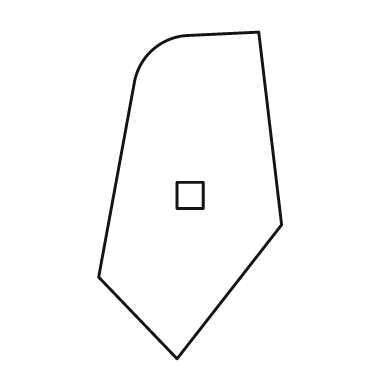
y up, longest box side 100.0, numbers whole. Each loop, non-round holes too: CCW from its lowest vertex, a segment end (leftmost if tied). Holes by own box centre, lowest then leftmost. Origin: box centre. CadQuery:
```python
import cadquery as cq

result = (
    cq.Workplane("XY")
    .moveTo(-4.0, -50.0)
    .lineTo(28.0, -9.0)
    .lineTo(21.0, 50.0)
    .lineTo(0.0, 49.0)
    .threePointArc((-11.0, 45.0), (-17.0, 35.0))
    .lineTo(-28.0, -25.0)
    .close()
    .moveTo(-4.0, -4.0)
    .lineTo(4.0, -4.0)
    .lineTo(4.0, 4.0)
    .lineTo(-4.0, 4.0)
    .close()
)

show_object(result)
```